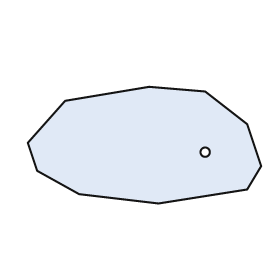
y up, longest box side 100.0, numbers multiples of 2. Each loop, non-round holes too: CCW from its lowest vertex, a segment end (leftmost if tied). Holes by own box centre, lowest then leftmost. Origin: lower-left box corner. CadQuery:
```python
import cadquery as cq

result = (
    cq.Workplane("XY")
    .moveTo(56.0, 0.0)
    .lineTo(94.0, 6.0)
    .lineTo(100.0, 16.0)
    .lineTo(94.0, 34.0)
    .lineTo(76.0, 48.0)
    .lineTo(52.0, 50.0)
    .lineTo(16.0, 44.0)
    .lineTo(0.0, 26.0)
    .lineTo(4.0, 14.0)
    .lineTo(22.0, 4.0)
    .close()
    .moveTo(76.0, 22.0)
    .circle(2.0)
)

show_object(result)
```